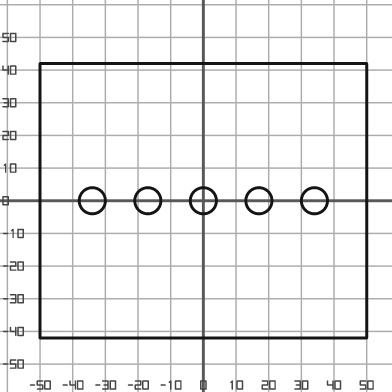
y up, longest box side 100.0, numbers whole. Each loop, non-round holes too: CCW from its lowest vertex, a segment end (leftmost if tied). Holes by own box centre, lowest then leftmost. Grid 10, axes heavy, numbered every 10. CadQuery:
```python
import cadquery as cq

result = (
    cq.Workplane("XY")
    .moveTo(-50.0, -42.0)
    .lineTo(50.0, -42.0)
    .lineTo(50.0, 42.0)
    .lineTo(-50.0, 42.0)
    .close()
    .moveTo(-34.0, 0.0)
    .circle(4.0)
    .moveTo(-17.0, 0.0)
    .circle(4.0)
    .moveTo(0.0, 0.0)
    .circle(4.0)
    .moveTo(17.0, 0.0)
    .circle(4.0)
    .moveTo(34.0, 0.0)
    .circle(4.0)
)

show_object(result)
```